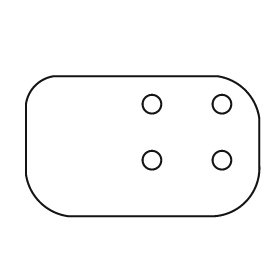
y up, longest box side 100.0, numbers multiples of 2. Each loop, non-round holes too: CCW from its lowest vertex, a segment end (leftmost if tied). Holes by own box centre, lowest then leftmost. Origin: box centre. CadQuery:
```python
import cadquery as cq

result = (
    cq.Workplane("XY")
    .moveTo(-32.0, -30.0)
    .lineTo(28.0, -30.0)
    .threePointArc((44.0, -24.0), (50.0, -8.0))
    .lineTo(50.0, 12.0)
    .threePointArc((44.0, 24.0), (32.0, 30.0))
    .lineTo(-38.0, 30.0)
    .threePointArc((-46.0, 26.0), (-50.0, 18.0))
    .lineTo(-50.0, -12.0)
    .threePointArc((-44.0, -24.0), (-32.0, -30.0))
    .close()
    .moveTo(4.0, -6.0)
    .circle(4.0)
    .moveTo(34.0, -6.0)
    .circle(4.0)
    .moveTo(4.0, 18.0)
    .circle(4.0)
    .moveTo(34.0, 18.0)
    .circle(4.0)
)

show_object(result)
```